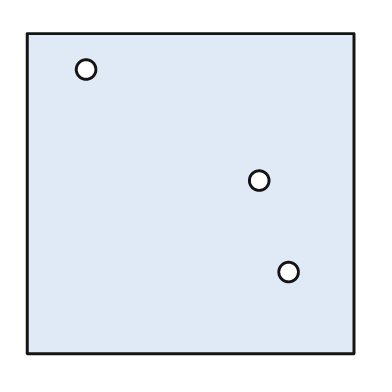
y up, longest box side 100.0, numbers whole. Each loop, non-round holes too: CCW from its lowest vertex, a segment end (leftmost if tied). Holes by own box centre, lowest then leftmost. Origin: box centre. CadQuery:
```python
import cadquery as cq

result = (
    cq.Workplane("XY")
    .moveTo(-50.0, -49.0)
    .lineTo(50.0, -49.0)
    .lineTo(50.0, 49.0)
    .lineTo(-50.0, 49.0)
    .close()
    .moveTo(30.0, -24.0)
    .circle(3.0)
    .moveTo(21.0, 4.0)
    .circle(3.0)
    .moveTo(-32.0, 38.0)
    .circle(3.0)
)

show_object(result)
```